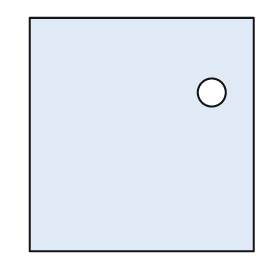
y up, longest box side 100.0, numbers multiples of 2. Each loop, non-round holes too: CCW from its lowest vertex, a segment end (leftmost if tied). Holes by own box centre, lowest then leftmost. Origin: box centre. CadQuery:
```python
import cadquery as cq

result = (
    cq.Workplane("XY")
    .moveTo(-48.0, -50.0)
    .lineTo(48.0, -50.0)
    .lineTo(48.0, 50.0)
    .lineTo(-48.0, 50.0)
    .close()
    .moveTo(30.0, 18.0)
    .circle(6.0)
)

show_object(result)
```